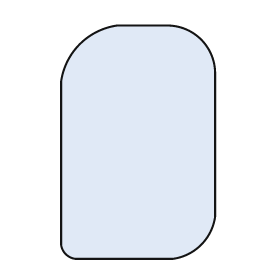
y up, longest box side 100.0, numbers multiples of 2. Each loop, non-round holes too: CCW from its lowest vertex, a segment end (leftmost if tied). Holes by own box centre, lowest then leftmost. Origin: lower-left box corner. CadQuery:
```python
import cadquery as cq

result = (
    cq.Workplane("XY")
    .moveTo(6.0, 0.0)
    .lineTo(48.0, 0.0)
    .threePointArc((60.0, 6.0), (66.0, 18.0))
    .lineTo(66.0, 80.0)
    .threePointArc((60.0, 94.0), (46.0, 100.0))
    .lineTo(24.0, 100.0)
    .threePointArc((8.0, 92.0), (0.0, 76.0))
    .lineTo(0.0, 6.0)
    .threePointArc((2.0, 2.0), (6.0, 0.0))
    .close()
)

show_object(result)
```